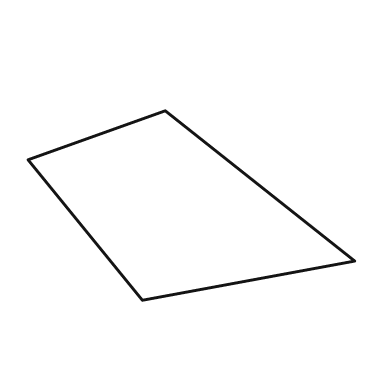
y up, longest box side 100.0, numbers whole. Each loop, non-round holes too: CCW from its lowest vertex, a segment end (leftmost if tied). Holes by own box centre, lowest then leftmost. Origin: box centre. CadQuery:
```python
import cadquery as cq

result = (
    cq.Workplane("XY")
    .moveTo(-15.0, -29.0)
    .lineTo(50.0, -17.0)
    .lineTo(-8.0, 29.0)
    .lineTo(-50.0, 14.0)
    .close()
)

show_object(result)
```